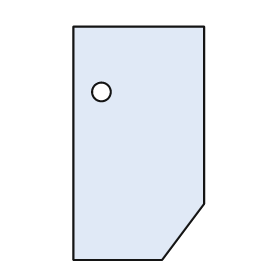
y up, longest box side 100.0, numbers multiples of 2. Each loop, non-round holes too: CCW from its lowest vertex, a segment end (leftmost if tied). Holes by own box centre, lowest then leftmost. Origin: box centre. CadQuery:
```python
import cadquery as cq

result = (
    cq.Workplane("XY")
    .moveTo(-28.0, -50.0)
    .lineTo(10.0, -50.0)
    .lineTo(28.0, -26.0)
    .lineTo(28.0, 50.0)
    .lineTo(-28.0, 50.0)
    .close()
    .moveTo(-16.0, 22.0)
    .circle(4.0)
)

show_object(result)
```